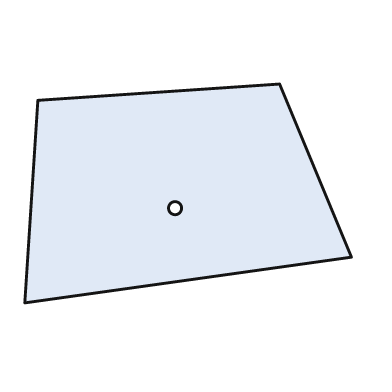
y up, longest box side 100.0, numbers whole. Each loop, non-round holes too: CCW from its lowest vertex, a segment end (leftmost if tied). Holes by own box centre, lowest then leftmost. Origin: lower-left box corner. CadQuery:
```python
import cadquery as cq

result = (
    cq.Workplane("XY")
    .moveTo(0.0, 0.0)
    .lineTo(100.0, 14.0)
    .lineTo(78.0, 67.0)
    .lineTo(4.0, 62.0)
    .close()
    .moveTo(46.0, 29.0)
    .circle(2.0)
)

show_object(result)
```